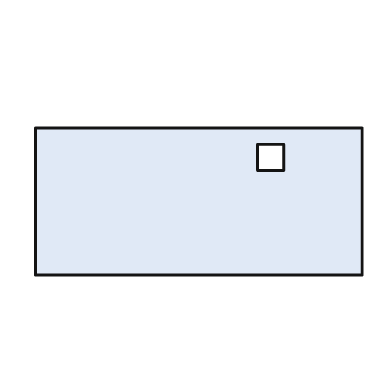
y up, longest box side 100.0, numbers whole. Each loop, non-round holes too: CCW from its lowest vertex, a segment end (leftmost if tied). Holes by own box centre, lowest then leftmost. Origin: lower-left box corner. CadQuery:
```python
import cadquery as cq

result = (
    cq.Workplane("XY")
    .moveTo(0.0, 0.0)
    .lineTo(100.0, 0.0)
    .lineTo(100.0, 45.0)
    .lineTo(0.0, 45.0)
    .close()
    .moveTo(68.0, 32.0)
    .lineTo(76.0, 32.0)
    .lineTo(76.0, 40.0)
    .lineTo(68.0, 40.0)
    .close()
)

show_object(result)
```